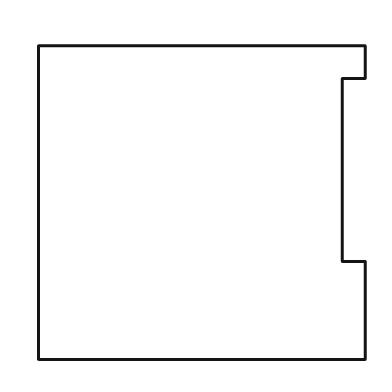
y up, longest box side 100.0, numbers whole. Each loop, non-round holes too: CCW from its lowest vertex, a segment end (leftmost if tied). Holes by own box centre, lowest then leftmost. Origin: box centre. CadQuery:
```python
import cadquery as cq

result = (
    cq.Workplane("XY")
    .moveTo(-50.0, -48.0)
    .lineTo(50.0, -48.0)
    .lineTo(50.0, -18.0)
    .lineTo(43.0, -18.0)
    .lineTo(43.0, 38.0)
    .lineTo(50.0, 38.0)
    .lineTo(50.0, 48.0)
    .lineTo(-50.0, 48.0)
    .close()
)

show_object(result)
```